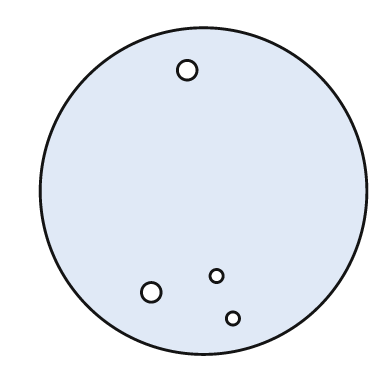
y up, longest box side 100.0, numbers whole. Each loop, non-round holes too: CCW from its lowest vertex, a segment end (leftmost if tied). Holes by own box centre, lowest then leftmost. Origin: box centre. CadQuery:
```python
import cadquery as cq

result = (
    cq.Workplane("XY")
    .moveTo(0.0, 0.0)
    .circle(50.0)
    .moveTo(9.0, -39.0)
    .circle(2.0)
    .moveTo(-16.0, -31.0)
    .circle(3.0)
    .moveTo(4.0, -26.0)
    .circle(2.0)
    .moveTo(-5.0, 37.0)
    .circle(3.0)
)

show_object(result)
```